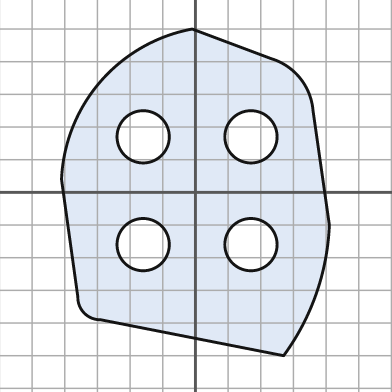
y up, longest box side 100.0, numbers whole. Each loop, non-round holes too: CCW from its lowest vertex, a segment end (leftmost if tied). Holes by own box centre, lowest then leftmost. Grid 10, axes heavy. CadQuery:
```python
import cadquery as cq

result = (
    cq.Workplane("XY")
    .moveTo(27.0, -50.0)
    .threePointArc((37.0, -31.0), (41.0, -10.0))
    .lineTo(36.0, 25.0)
    .threePointArc((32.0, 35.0), (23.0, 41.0))
    .lineTo(-1.0, 50.0)
    .threePointArc((-29.0, 34.0), (-41.0, 4.0))
    .lineTo(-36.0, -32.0)
    .threePointArc((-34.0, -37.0), (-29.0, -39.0))
    .close()
    .moveTo(-16.0, -16.0)
    .circle(8.0)
    .moveTo(17.0, -16.0)
    .circle(8.0)
    .moveTo(-16.0, 17.0)
    .circle(8.0)
    .moveTo(17.0, 17.0)
    .circle(8.0)
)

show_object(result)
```